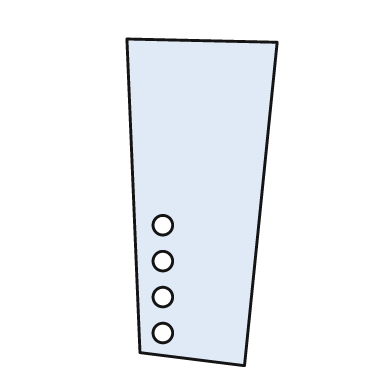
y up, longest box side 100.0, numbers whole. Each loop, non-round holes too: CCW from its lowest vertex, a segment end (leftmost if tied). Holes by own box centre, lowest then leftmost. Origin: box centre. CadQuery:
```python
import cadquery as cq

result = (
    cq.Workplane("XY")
    .moveTo(13.0, -50.0)
    .lineTo(23.0, 49.0)
    .lineTo(-23.0, 50.0)
    .lineTo(-19.0, -46.0)
    .close()
    .moveTo(-12.0, -40.0)
    .circle(3.0)
    .moveTo(-12.0, -29.0)
    .circle(3.0)
    .moveTo(-12.0, -18.0)
    .circle(3.0)
    .moveTo(-12.0, -7.0)
    .circle(3.0)
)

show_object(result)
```